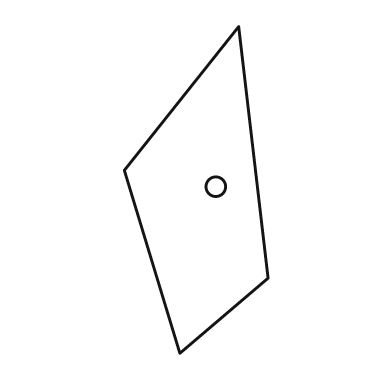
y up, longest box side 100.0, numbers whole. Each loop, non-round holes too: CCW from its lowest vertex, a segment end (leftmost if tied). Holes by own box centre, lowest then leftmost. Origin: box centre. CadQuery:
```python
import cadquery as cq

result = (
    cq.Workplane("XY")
    .moveTo(-5.0, -50.0)
    .lineTo(22.0, -27.0)
    .lineTo(13.0, 50.0)
    .lineTo(-22.0, 6.0)
    .close()
    .moveTo(6.0, 1.0)
    .circle(3.0)
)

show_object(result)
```